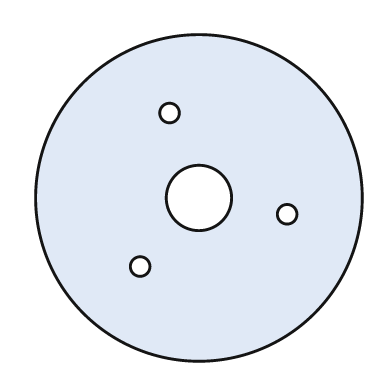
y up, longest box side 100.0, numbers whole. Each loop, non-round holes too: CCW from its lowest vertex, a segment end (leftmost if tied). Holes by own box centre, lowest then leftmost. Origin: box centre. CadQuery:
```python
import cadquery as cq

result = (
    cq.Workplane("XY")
    .moveTo(0.0, 0.0)
    .circle(50.0)
    .moveTo(-18.0, -21.0)
    .circle(3.0)
    .moveTo(27.0, -5.0)
    .circle(3.0)
    .moveTo(0.0, 0.0)
    .circle(10.0)
    .moveTo(-9.0, 26.0)
    .circle(3.0)
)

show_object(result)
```